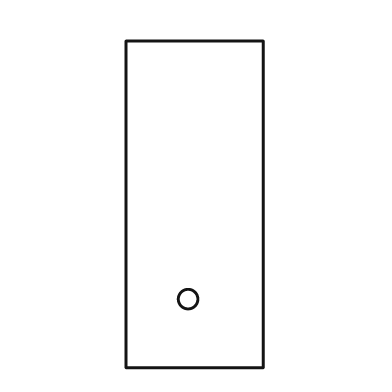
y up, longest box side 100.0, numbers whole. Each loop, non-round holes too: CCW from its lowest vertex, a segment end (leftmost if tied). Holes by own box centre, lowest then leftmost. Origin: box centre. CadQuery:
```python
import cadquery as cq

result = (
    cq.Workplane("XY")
    .moveTo(-21.0, -50.0)
    .lineTo(21.0, -50.0)
    .lineTo(21.0, 50.0)
    .lineTo(-21.0, 50.0)
    .close()
    .moveTo(-2.0, -29.0)
    .circle(3.0)
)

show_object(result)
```